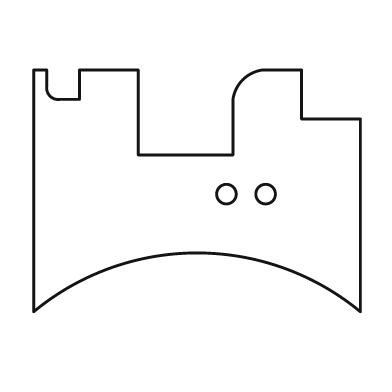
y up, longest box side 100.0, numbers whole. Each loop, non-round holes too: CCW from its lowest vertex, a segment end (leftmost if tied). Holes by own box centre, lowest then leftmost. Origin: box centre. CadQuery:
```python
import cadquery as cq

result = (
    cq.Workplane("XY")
    .moveTo(-50.0, -37.0)
    .threePointArc((0.0, -19.0), (50.0, -37.0))
    .lineTo(50.0, 22.0)
    .lineTo(32.0, 22.0)
    .lineTo(32.0, 37.0)
    .lineTo(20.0, 37.0)
    .threePointArc((14.0, 34.0), (11.0, 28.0))
    .lineTo(11.0, 11.0)
    .lineTo(-18.0, 11.0)
    .lineTo(-18.0, 37.0)
    .lineTo(-36.0, 37.0)
    .lineTo(-36.0, 28.0)
    .lineTo(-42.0, 28.0)
    .threePointArc((-45.0, 29.0), (-46.0, 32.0))
    .lineTo(-46.0, 37.0)
    .lineTo(-50.0, 37.0)
    .close()
    .moveTo(9.0, -1.0)
    .circle(3.0)
    .moveTo(21.0, -1.0)
    .circle(3.0)
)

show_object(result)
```